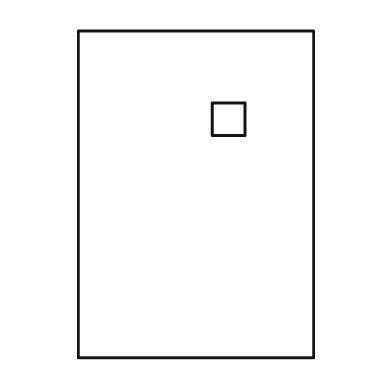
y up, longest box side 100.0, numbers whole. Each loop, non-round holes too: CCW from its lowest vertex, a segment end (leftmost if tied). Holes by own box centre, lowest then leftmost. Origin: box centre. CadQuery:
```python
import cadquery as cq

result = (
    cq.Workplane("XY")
    .moveTo(-36.0, -50.0)
    .lineTo(36.0, -50.0)
    .lineTo(36.0, 50.0)
    .lineTo(-36.0, 50.0)
    .close()
    .moveTo(5.0, 18.0)
    .lineTo(15.0, 18.0)
    .lineTo(15.0, 28.0)
    .lineTo(5.0, 28.0)
    .close()
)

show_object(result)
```